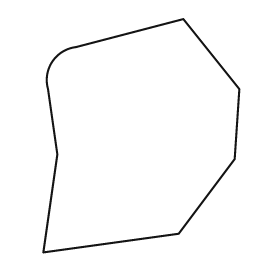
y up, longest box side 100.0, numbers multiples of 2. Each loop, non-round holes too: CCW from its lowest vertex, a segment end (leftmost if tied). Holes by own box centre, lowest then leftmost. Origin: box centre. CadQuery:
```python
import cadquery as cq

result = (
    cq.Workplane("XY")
    .moveTo(-42.0, -50.0)
    .lineTo(16.0, -42.0)
    .lineTo(40.0, -10.0)
    .lineTo(42.0, 20.0)
    .lineTo(18.0, 50.0)
    .lineTo(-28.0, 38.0)
    .threePointArc((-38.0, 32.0), (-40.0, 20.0))
    .lineTo(-36.0, -8.0)
    .close()
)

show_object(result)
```